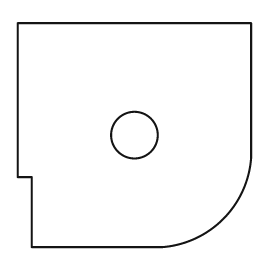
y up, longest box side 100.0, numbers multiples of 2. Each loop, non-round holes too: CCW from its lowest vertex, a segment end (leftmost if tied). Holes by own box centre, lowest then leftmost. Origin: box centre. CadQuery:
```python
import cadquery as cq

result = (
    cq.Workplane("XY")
    .moveTo(-44.0, -48.0)
    .lineTo(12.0, -48.0)
    .threePointArc((38.0, -36.0), (50.0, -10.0))
    .lineTo(50.0, 48.0)
    .lineTo(-50.0, 48.0)
    .lineTo(-50.0, -18.0)
    .lineTo(-44.0, -18.0)
    .close()
    .moveTo(0.0, 0.0)
    .circle(10.0)
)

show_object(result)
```